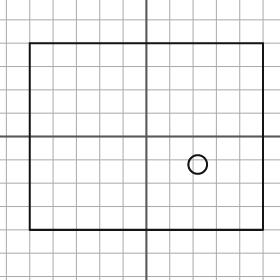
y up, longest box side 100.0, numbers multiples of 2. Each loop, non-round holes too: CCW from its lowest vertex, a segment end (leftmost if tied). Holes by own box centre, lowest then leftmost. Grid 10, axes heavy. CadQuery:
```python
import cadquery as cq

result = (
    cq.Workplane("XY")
    .moveTo(-50.0, -40.0)
    .lineTo(50.0, -40.0)
    .lineTo(50.0, 40.0)
    .lineTo(-50.0, 40.0)
    .close()
    .moveTo(22.0, -12.0)
    .circle(4.0)
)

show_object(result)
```